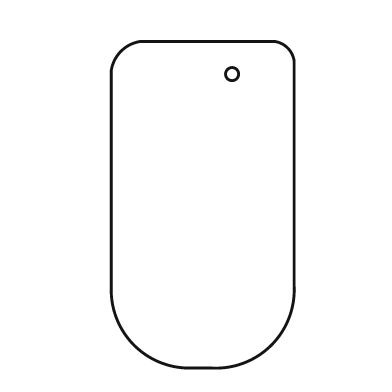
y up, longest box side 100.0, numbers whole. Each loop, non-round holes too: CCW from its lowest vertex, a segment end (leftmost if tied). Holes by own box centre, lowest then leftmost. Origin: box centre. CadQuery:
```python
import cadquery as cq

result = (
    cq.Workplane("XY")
    .moveTo(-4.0, -50.0)
    .lineTo(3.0, -50.0)
    .threePointArc((21.0, -43.0), (28.0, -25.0))
    .lineTo(28.0, 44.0)
    .threePointArc((26.0, 48.0), (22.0, 50.0))
    .lineTo(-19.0, 50.0)
    .threePointArc((-25.0, 47.0), (-28.0, 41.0))
    .lineTo(-28.0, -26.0)
    .threePointArc((-21.0, -43.0), (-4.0, -50.0))
    .close()
    .moveTo(9.0, 40.0)
    .circle(2.0)
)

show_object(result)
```